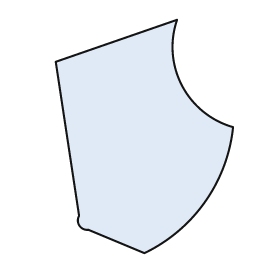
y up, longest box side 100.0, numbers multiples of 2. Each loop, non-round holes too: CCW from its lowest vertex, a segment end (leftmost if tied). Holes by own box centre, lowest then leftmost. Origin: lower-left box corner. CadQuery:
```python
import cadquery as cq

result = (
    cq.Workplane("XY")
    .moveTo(38.0, 0.0)
    .threePointArc((64.0, 22.0), (76.0, 54.0))
    .threePointArc((54.0, 72.0), (52.0, 100.0))
    .lineTo(0.0, 82.0)
    .lineTo(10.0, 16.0)
    .threePointArc((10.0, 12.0), (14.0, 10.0))
    .close()
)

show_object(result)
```